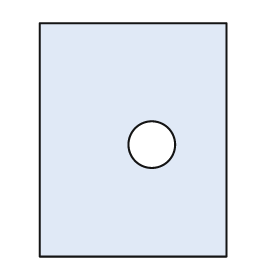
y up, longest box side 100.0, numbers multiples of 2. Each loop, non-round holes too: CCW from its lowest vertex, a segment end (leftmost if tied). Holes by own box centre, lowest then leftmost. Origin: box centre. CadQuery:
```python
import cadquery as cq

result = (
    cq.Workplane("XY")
    .moveTo(-40.0, -50.0)
    .lineTo(40.0, -50.0)
    .lineTo(40.0, 50.0)
    .lineTo(-40.0, 50.0)
    .close()
    .moveTo(8.0, -2.0)
    .circle(10.0)
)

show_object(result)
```